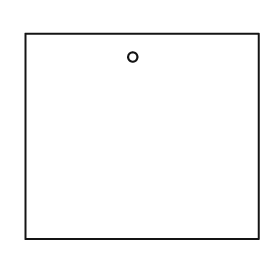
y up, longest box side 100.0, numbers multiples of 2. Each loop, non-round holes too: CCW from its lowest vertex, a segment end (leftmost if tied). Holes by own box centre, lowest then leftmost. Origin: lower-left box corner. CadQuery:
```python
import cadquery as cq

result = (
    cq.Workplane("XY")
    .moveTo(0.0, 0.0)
    .lineTo(100.0, 0.0)
    .lineTo(100.0, 88.0)
    .lineTo(0.0, 88.0)
    .close()
    .moveTo(46.0, 78.0)
    .circle(2.0)
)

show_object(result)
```